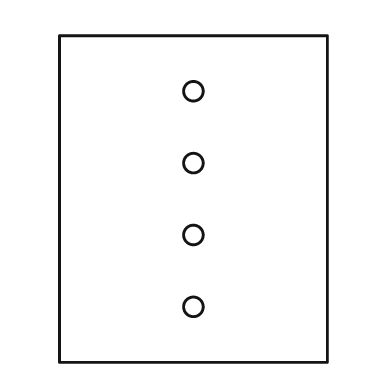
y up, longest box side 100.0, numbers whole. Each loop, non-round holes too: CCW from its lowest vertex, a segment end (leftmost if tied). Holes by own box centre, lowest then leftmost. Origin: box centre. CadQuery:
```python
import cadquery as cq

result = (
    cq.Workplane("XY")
    .moveTo(-41.0, -50.0)
    .lineTo(41.0, -50.0)
    .lineTo(41.0, 50.0)
    .lineTo(-41.0, 50.0)
    .close()
    .moveTo(0.0, -33.0)
    .circle(3.0)
    .moveTo(0.0, -11.0)
    .circle(3.0)
    .moveTo(0.0, 11.0)
    .circle(3.0)
    .moveTo(0.0, 33.0)
    .circle(3.0)
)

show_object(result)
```